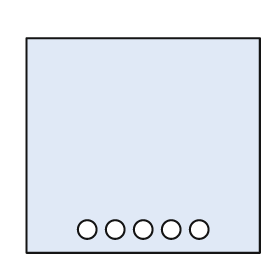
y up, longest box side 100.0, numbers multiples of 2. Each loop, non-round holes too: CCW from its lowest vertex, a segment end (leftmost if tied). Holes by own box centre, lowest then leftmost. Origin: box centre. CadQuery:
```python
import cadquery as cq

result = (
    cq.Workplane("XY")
    .moveTo(-50.0, -46.0)
    .lineTo(50.0, -46.0)
    .lineTo(50.0, 46.0)
    .lineTo(-50.0, 46.0)
    .close()
    .moveTo(-24.0, -36.0)
    .circle(4.0)
    .moveTo(-12.0, -36.0)
    .circle(4.0)
    .moveTo(0.0, -36.0)
    .circle(4.0)
    .moveTo(12.0, -36.0)
    .circle(4.0)
    .moveTo(24.0, -36.0)
    .circle(4.0)
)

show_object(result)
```